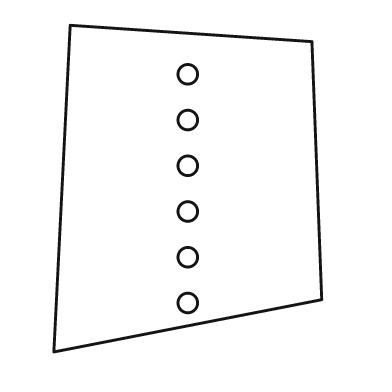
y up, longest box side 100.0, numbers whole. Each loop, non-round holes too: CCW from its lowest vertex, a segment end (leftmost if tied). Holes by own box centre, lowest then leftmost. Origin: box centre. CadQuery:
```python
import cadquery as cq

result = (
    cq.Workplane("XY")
    .moveTo(-41.0, -50.0)
    .lineTo(41.0, -34.0)
    .lineTo(38.0, 45.0)
    .lineTo(-36.0, 50.0)
    .close()
    .moveTo(0.0, -35.0)
    .circle(3.0)
    .moveTo(0.0, -21.0)
    .circle(3.0)
    .moveTo(0.0, -7.0)
    .circle(3.0)
    .moveTo(0.0, 7.0)
    .circle(3.0)
    .moveTo(0.0, 21.0)
    .circle(3.0)
    .moveTo(0.0, 35.0)
    .circle(3.0)
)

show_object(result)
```